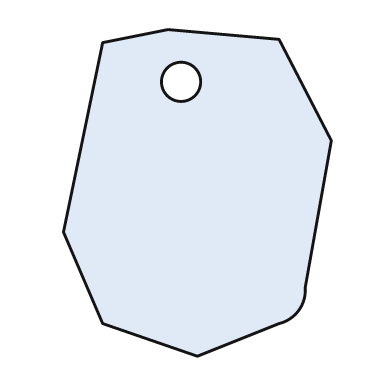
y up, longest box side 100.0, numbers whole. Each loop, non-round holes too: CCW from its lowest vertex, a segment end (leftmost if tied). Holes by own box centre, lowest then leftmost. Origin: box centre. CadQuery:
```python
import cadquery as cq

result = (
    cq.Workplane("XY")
    .moveTo(0.0, -50.0)
    .lineTo(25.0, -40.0)
    .threePointArc((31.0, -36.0), (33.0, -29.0))
    .lineTo(41.0, 16.0)
    .lineTo(25.0, 47.0)
    .lineTo(-9.0, 50.0)
    .lineTo(-29.0, 46.0)
    .lineTo(-41.0, -12.0)
    .lineTo(-29.0, -40.0)
    .close()
    .moveTo(-5.0, 34.0)
    .circle(6.0)
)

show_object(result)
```